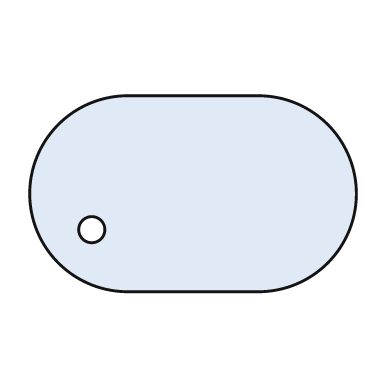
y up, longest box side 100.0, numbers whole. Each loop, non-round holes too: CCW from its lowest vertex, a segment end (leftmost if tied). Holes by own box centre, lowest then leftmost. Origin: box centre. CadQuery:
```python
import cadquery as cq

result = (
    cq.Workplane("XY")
    .moveTo(-20.0, -30.0)
    .lineTo(20.0, -30.0)
    .threePointArc((50.0, 0.0), (20.0, 30.0))
    .lineTo(-20.0, 30.0)
    .threePointArc((-50.0, 0.0), (-20.0, -30.0))
    .close()
    .moveTo(-31.0, -11.0)
    .circle(4.0)
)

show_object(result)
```